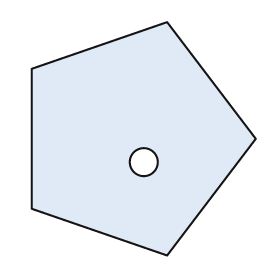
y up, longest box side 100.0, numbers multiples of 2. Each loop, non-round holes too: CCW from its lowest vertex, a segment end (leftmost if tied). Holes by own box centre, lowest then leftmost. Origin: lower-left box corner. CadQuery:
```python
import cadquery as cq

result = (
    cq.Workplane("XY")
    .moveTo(58.0, 0.0)
    .lineTo(96.0, 50.0)
    .lineTo(58.0, 100.0)
    .lineTo(0.0, 80.0)
    .lineTo(0.0, 20.0)
    .close()
    .moveTo(48.0, 40.0)
    .circle(6.0)
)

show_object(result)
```